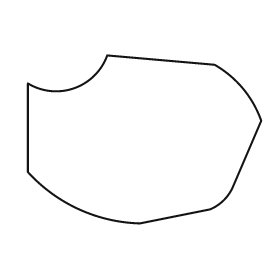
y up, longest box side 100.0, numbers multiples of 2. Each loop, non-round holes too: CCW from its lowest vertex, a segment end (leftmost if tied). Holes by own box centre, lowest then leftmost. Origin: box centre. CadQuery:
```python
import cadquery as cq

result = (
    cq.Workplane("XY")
    .moveTo(-2.0, -36.0)
    .lineTo(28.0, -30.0)
    .threePointArc((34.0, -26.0), (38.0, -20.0))
    .lineTo(50.0, 8.0)
    .threePointArc((42.0, 22.0), (30.0, 32.0))
    .lineTo(-16.0, 36.0)
    .threePointArc((-30.0, 22.0), (-50.0, 24.0))
    .lineTo(-50.0, -14.0)
    .threePointArc((-28.0, -30.0), (-2.0, -36.0))
    .close()
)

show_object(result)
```